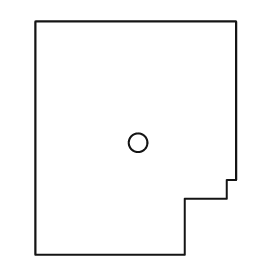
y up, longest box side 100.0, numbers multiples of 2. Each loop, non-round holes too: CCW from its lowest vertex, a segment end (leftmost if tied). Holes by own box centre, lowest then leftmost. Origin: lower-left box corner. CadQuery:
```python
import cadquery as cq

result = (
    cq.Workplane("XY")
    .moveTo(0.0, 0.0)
    .lineTo(64.0, 0.0)
    .lineTo(64.0, 24.0)
    .lineTo(82.0, 24.0)
    .lineTo(82.0, 32.0)
    .lineTo(86.0, 32.0)
    .lineTo(86.0, 100.0)
    .lineTo(0.0, 100.0)
    .close()
    .moveTo(44.0, 48.0)
    .circle(4.0)
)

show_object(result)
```